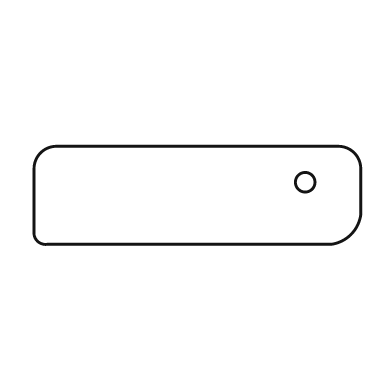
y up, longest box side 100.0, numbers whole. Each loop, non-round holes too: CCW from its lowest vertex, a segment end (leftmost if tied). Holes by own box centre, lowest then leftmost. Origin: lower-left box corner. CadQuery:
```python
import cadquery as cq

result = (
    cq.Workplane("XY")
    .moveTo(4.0, 0.0)
    .lineTo(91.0, 0.0)
    .threePointArc((97.0, 3.0), (100.0, 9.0))
    .lineTo(100.0, 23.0)
    .threePointArc((98.0, 28.0), (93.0, 30.0))
    .lineTo(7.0, 30.0)
    .threePointArc((2.0, 28.0), (0.0, 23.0))
    .lineTo(0.0, 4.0)
    .threePointArc((1.0, 1.0), (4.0, 0.0))
    .close()
    .moveTo(83.0, 19.0)
    .circle(3.0)
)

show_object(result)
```